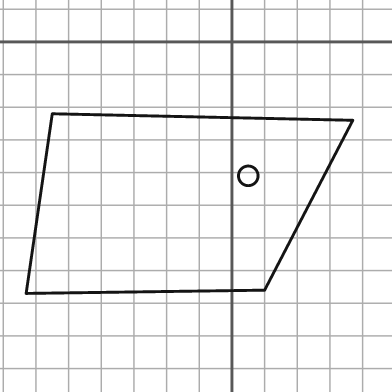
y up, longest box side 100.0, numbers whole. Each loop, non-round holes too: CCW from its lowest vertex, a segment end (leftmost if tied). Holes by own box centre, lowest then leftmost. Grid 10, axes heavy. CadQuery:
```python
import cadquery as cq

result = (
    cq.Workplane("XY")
    .moveTo(-63.0, -77.0)
    .lineTo(10.0, -76.0)
    .lineTo(37.0, -24.0)
    .lineTo(-55.0, -22.0)
    .close()
    .moveTo(5.0, -41.0)
    .circle(3.0)
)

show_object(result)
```